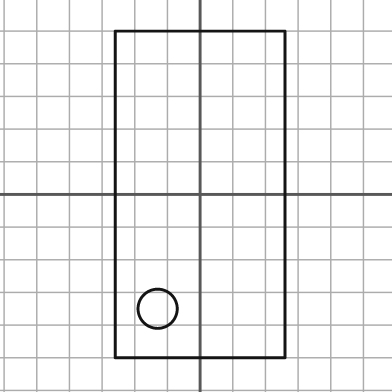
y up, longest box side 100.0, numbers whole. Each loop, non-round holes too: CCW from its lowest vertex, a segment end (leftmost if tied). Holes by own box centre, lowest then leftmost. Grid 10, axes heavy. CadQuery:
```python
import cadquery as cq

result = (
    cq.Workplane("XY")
    .moveTo(-26.0, -50.0)
    .lineTo(26.0, -50.0)
    .lineTo(26.0, 50.0)
    .lineTo(-26.0, 50.0)
    .close()
    .moveTo(-13.0, -35.0)
    .circle(6.0)
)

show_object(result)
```